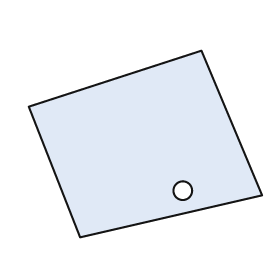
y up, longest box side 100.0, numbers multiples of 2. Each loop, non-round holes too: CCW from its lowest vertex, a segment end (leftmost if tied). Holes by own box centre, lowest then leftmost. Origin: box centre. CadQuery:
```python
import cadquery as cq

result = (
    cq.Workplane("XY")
    .moveTo(-28.0, -40.0)
    .lineTo(50.0, -22.0)
    .lineTo(24.0, 40.0)
    .lineTo(-50.0, 16.0)
    .close()
    .moveTo(16.0, -20.0)
    .circle(4.0)
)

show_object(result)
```